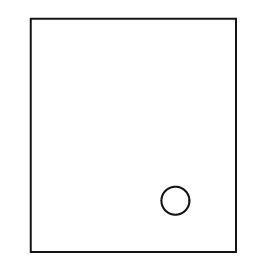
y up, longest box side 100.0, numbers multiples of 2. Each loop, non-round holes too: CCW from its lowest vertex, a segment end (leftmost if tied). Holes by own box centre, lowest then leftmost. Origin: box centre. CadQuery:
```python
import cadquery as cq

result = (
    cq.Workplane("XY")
    .moveTo(-44.0, -50.0)
    .lineTo(44.0, -50.0)
    .lineTo(44.0, 50.0)
    .lineTo(-44.0, 50.0)
    .close()
    .moveTo(18.0, -28.0)
    .circle(6.0)
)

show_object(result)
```